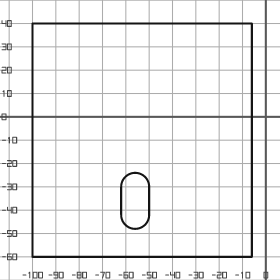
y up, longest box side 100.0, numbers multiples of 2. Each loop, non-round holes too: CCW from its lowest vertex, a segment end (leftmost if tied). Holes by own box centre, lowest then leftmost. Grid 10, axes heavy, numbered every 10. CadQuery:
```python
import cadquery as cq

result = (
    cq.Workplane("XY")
    .moveTo(-100.0, -60.0)
    .lineTo(-6.0, -60.0)
    .lineTo(-6.0, 40.0)
    .lineTo(-100.0, 40.0)
    .close()
    .moveTo(-62.0, -42.0)
    .threePointArc((-56.0, -48.0), (-50.0, -42.0))
    .lineTo(-50.0, -30.0)
    .threePointArc((-56.0, -24.0), (-62.0, -30.0))
    .close()
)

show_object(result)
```